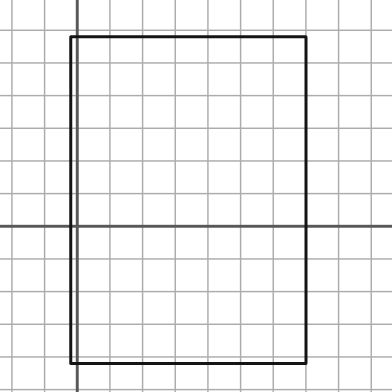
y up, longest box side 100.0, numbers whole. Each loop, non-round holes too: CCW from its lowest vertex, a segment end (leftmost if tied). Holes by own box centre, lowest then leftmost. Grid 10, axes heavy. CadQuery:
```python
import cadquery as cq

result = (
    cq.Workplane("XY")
    .moveTo(-2.0, -42.0)
    .lineTo(70.0, -42.0)
    .lineTo(70.0, 58.0)
    .lineTo(-2.0, 58.0)
    .close()
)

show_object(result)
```